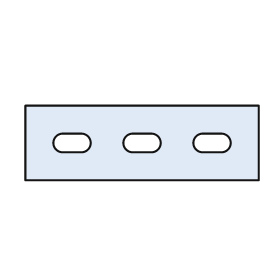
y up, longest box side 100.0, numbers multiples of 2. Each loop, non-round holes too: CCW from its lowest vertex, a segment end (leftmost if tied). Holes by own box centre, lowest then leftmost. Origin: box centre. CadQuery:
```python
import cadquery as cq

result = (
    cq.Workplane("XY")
    .moveTo(-50.0, -16.0)
    .lineTo(50.0, -16.0)
    .lineTo(50.0, 16.0)
    .lineTo(-50.0, 16.0)
    .close()
    .moveTo(-34.0, -4.0)
    .lineTo(-26.0, -4.0)
    .threePointArc((-22.0, 0.0), (-26.0, 4.0))
    .lineTo(-34.0, 4.0)
    .threePointArc((-38.0, 0.0), (-34.0, -4.0))
    .close()
    .moveTo(-4.0, -4.0)
    .lineTo(4.0, -4.0)
    .threePointArc((8.0, 0.0), (4.0, 4.0))
    .lineTo(-4.0, 4.0)
    .threePointArc((-8.0, 0.0), (-4.0, -4.0))
    .close()
    .moveTo(26.0, -4.0)
    .lineTo(34.0, -4.0)
    .threePointArc((38.0, 0.0), (34.0, 4.0))
    .lineTo(26.0, 4.0)
    .threePointArc((22.0, 0.0), (26.0, -4.0))
    .close()
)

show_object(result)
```